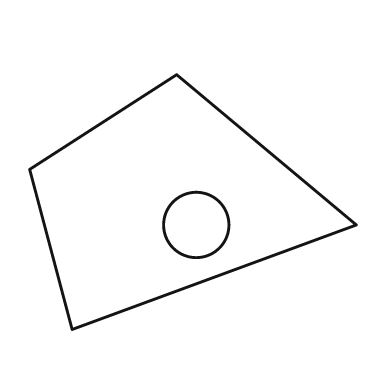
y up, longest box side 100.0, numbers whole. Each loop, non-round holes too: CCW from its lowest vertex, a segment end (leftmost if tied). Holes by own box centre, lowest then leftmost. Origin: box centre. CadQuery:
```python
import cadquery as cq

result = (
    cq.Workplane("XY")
    .moveTo(-37.0, -39.0)
    .lineTo(50.0, -7.0)
    .lineTo(-5.0, 39.0)
    .lineTo(-50.0, 10.0)
    .close()
    .moveTo(1.0, -7.0)
    .circle(10.0)
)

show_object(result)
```